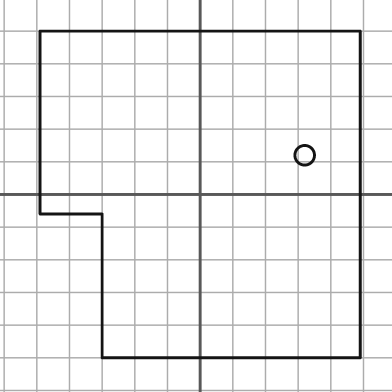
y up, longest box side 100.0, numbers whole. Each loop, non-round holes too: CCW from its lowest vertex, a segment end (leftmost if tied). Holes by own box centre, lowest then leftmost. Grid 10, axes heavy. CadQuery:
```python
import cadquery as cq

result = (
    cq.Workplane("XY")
    .moveTo(-30.0, -50.0)
    .lineTo(49.0, -50.0)
    .lineTo(49.0, 50.0)
    .lineTo(-49.0, 50.0)
    .lineTo(-49.0, -6.0)
    .lineTo(-30.0, -6.0)
    .close()
    .moveTo(32.0, 12.0)
    .circle(3.0)
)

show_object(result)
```